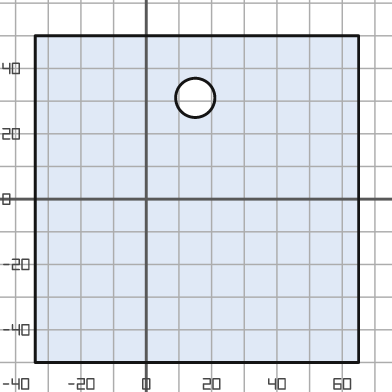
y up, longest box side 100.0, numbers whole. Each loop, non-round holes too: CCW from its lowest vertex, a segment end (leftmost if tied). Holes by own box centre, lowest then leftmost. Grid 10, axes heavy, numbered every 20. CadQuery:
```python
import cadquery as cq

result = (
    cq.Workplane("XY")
    .moveTo(-34.0, -50.0)
    .lineTo(65.0, -50.0)
    .lineTo(65.0, 50.0)
    .lineTo(-34.0, 50.0)
    .close()
    .moveTo(15.0, 31.0)
    .circle(6.0)
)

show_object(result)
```